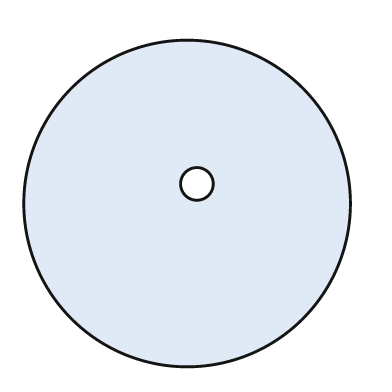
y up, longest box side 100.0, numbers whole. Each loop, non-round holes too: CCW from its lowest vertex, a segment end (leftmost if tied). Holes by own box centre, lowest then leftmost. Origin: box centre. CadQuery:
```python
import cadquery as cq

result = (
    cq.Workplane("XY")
    .moveTo(0.0, 0.0)
    .circle(50.0)
    .moveTo(3.0, 6.0)
    .circle(5.0)
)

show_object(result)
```